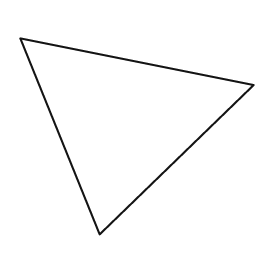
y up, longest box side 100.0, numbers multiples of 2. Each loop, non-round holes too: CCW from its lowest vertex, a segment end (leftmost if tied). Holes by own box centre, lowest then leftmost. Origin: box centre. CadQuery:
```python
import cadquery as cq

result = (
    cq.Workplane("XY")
    .moveTo(-16.0, -42.0)
    .lineTo(50.0, 22.0)
    .lineTo(-50.0, 42.0)
    .close()
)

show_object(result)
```